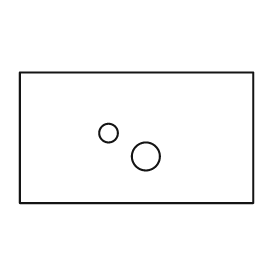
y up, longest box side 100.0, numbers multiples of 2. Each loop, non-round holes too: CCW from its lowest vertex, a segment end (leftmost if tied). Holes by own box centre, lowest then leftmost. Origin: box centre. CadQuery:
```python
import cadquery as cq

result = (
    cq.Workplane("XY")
    .moveTo(-50.0, -28.0)
    .lineTo(50.0, -28.0)
    .lineTo(50.0, 28.0)
    .lineTo(-50.0, 28.0)
    .close()
    .moveTo(4.0, -8.0)
    .circle(6.0)
    .moveTo(-12.0, 2.0)
    .circle(4.0)
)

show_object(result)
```